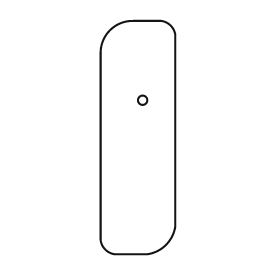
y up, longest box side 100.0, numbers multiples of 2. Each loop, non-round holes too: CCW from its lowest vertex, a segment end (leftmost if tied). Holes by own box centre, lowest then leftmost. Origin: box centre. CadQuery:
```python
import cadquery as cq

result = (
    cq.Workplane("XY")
    .moveTo(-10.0, -50.0)
    .lineTo(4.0, -50.0)
    .threePointArc((12.0, -46.0), (16.0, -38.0))
    .lineTo(16.0, 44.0)
    .threePointArc((14.0, 48.0), (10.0, 50.0))
    .lineTo(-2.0, 50.0)
    .threePointArc((-12.0, 46.0), (-16.0, 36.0))
    .lineTo(-16.0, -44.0)
    .threePointArc((-14.0, -48.0), (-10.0, -50.0))
    .close()
    .moveTo(2.0, 16.0)
    .circle(2.0)
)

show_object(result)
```